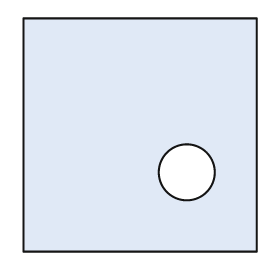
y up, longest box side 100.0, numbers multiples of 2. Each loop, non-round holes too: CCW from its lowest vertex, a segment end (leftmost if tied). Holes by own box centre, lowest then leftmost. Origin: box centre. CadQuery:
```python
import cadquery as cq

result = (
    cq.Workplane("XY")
    .moveTo(-50.0, -50.0)
    .lineTo(50.0, -50.0)
    .lineTo(50.0, 50.0)
    .lineTo(-50.0, 50.0)
    .close()
    .moveTo(20.0, -16.0)
    .circle(12.0)
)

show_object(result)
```